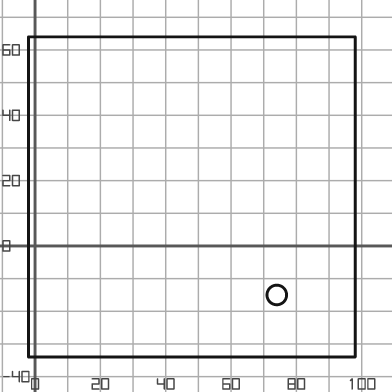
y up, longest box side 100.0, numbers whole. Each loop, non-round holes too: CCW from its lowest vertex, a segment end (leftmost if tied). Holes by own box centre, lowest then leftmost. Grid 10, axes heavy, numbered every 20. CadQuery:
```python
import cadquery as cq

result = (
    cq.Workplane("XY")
    .moveTo(-2.0, -34.0)
    .lineTo(98.0, -34.0)
    .lineTo(98.0, 64.0)
    .lineTo(-2.0, 64.0)
    .close()
    .moveTo(74.0, -15.0)
    .circle(3.0)
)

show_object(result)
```